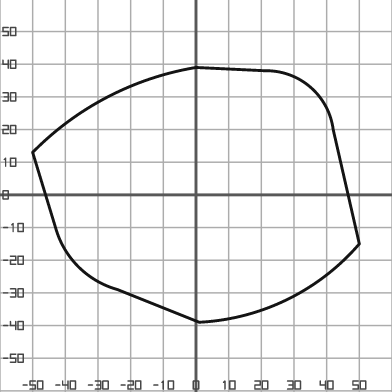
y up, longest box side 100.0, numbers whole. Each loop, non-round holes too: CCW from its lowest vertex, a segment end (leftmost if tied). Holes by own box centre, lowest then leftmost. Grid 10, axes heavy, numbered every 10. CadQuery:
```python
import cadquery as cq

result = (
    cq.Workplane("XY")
    .moveTo(1.0, -39.0)
    .threePointArc((28.0, -32.0), (50.0, -15.0))
    .lineTo(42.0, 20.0)
    .threePointArc((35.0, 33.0), (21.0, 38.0))
    .lineTo(0.0, 39.0)
    .threePointArc((-27.0, 30.0), (-50.0, 13.0))
    .lineTo(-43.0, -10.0)
    .threePointArc((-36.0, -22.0), (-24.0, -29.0))
    .close()
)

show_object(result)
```